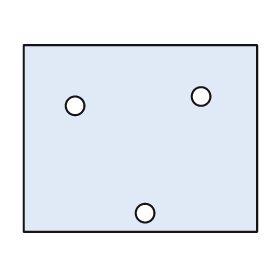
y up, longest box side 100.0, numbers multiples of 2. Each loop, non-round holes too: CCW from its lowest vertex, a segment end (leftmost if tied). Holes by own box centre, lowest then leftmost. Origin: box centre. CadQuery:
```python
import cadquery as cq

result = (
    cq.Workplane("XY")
    .moveTo(-50.0, -40.0)
    .lineTo(50.0, -40.0)
    .lineTo(50.0, 40.0)
    .lineTo(-50.0, 40.0)
    .close()
    .moveTo(2.0, -32.0)
    .circle(4.0)
    .moveTo(-28.0, 14.0)
    .circle(4.0)
    .moveTo(26.0, 18.0)
    .circle(4.0)
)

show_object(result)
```